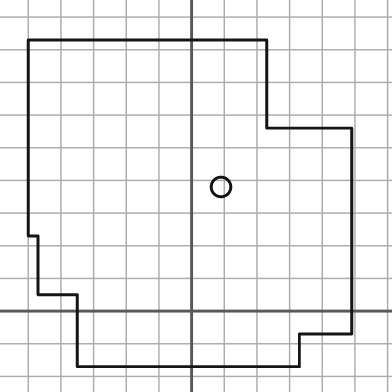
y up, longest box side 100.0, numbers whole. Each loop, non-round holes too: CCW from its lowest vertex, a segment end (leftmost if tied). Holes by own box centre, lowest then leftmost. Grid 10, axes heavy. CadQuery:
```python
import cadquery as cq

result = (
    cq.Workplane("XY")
    .moveTo(-35.0, -17.0)
    .lineTo(33.0, -17.0)
    .lineTo(33.0, -7.0)
    .lineTo(49.0, -7.0)
    .lineTo(49.0, 56.0)
    .lineTo(23.0, 56.0)
    .lineTo(23.0, 83.0)
    .lineTo(-50.0, 83.0)
    .lineTo(-50.0, 23.0)
    .lineTo(-47.0, 23.0)
    .lineTo(-47.0, 5.0)
    .lineTo(-35.0, 5.0)
    .close()
    .moveTo(9.0, 38.0)
    .circle(3.0)
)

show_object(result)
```